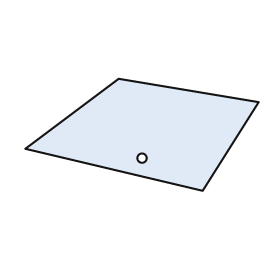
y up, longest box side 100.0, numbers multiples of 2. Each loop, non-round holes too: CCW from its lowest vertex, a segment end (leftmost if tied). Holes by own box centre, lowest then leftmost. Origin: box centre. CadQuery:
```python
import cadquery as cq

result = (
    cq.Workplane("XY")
    .moveTo(26.0, -24.0)
    .lineTo(50.0, 14.0)
    .lineTo(-10.0, 24.0)
    .lineTo(-50.0, -6.0)
    .close()
    .moveTo(0.0, -10.0)
    .circle(2.0)
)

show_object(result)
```